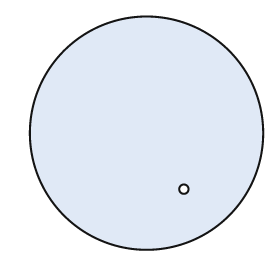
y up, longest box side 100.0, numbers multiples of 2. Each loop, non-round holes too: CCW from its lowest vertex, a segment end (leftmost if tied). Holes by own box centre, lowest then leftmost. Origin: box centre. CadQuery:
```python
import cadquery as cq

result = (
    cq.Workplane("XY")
    .moveTo(0.0, 0.0)
    .circle(50.0)
    .moveTo(16.0, -24.0)
    .circle(2.0)
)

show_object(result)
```